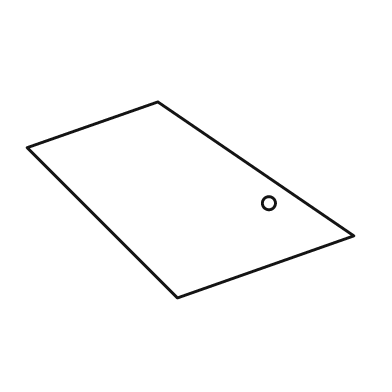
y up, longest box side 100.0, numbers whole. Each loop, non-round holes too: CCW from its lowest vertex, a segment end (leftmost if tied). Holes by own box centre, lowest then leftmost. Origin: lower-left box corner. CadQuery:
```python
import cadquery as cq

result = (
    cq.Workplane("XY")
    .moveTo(46.0, 0.0)
    .lineTo(100.0, 19.0)
    .lineTo(40.0, 60.0)
    .lineTo(0.0, 46.0)
    .close()
    .moveTo(74.0, 29.0)
    .circle(2.0)
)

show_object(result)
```